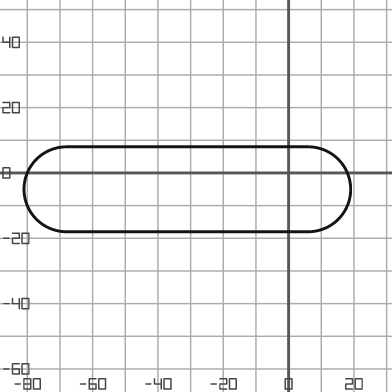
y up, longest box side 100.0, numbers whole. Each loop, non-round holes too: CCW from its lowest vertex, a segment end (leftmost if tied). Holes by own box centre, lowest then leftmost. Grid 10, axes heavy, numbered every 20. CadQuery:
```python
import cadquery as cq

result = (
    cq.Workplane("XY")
    .moveTo(-68.0, -18.0)
    .lineTo(6.0, -18.0)
    .threePointArc((19.0, -5.0), (6.0, 8.0))
    .lineTo(-68.0, 8.0)
    .threePointArc((-81.0, -5.0), (-68.0, -18.0))
    .close()
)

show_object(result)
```